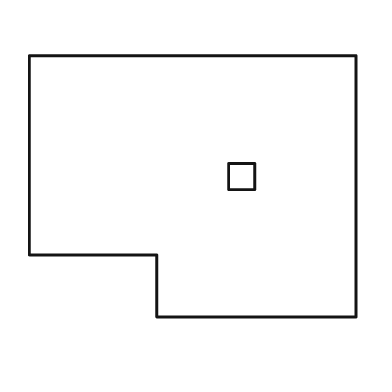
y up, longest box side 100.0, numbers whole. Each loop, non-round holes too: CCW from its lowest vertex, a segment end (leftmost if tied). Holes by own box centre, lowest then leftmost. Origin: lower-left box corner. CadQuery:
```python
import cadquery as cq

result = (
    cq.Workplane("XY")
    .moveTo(39.0, 0.0)
    .lineTo(100.0, 0.0)
    .lineTo(100.0, 80.0)
    .lineTo(0.0, 80.0)
    .lineTo(0.0, 19.0)
    .lineTo(39.0, 19.0)
    .close()
    .moveTo(61.0, 39.0)
    .lineTo(69.0, 39.0)
    .lineTo(69.0, 47.0)
    .lineTo(61.0, 47.0)
    .close()
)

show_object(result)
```